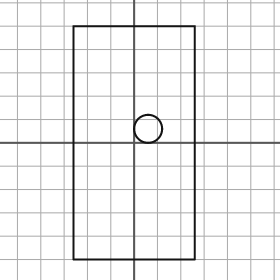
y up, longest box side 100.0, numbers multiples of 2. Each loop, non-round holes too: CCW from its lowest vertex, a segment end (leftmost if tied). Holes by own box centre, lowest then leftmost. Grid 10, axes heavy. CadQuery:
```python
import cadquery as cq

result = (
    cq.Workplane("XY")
    .moveTo(-26.0, -50.0)
    .lineTo(26.0, -50.0)
    .lineTo(26.0, 50.0)
    .lineTo(-26.0, 50.0)
    .close()
    .moveTo(6.0, 6.0)
    .circle(6.0)
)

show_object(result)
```